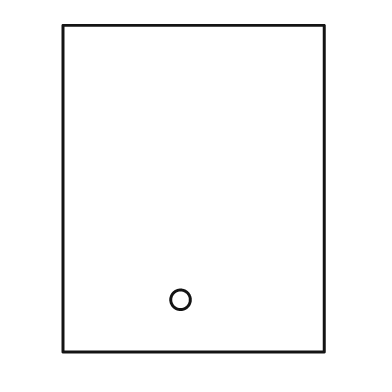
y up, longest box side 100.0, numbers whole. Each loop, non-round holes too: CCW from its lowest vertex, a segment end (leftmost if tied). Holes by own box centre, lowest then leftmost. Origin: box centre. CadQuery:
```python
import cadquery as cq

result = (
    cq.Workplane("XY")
    .moveTo(-40.0, -50.0)
    .lineTo(40.0, -50.0)
    .lineTo(40.0, 50.0)
    .lineTo(-40.0, 50.0)
    .close()
    .moveTo(-4.0, -34.0)
    .circle(3.0)
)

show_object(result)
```